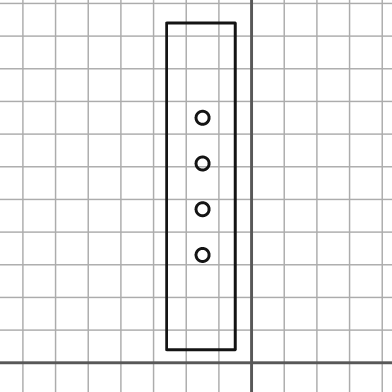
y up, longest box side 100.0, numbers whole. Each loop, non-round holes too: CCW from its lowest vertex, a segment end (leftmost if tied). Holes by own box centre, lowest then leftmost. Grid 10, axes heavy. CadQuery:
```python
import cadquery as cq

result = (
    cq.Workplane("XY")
    .moveTo(-26.0, 4.0)
    .lineTo(-5.0, 4.0)
    .lineTo(-5.0, 104.0)
    .lineTo(-26.0, 104.0)
    .close()
    .moveTo(-15.0, 33.0)
    .circle(2.0)
    .moveTo(-15.0, 47.0)
    .circle(2.0)
    .moveTo(-15.0, 61.0)
    .circle(2.0)
    .moveTo(-15.0, 75.0)
    .circle(2.0)
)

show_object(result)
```